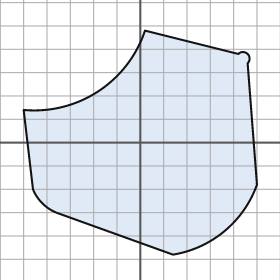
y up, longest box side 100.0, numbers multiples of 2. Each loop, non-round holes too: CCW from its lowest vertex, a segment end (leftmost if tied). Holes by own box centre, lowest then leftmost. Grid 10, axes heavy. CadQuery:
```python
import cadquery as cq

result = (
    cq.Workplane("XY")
    .moveTo(14.0, -48.0)
    .threePointArc((36.0, -38.0), (50.0, -18.0))
    .lineTo(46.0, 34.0)
    .threePointArc((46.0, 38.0), (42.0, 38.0))
    .lineTo(2.0, 48.0)
    .threePointArc((-18.0, 22.0), (-50.0, 14.0))
    .lineTo(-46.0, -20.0)
    .threePointArc((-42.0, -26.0), (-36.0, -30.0))
    .close()
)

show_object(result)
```